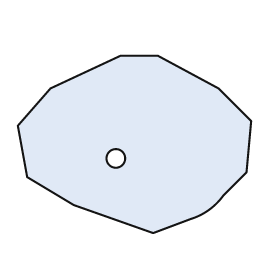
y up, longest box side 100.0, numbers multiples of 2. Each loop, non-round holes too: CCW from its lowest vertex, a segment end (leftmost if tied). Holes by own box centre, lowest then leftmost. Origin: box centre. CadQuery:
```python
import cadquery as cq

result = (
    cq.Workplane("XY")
    .moveTo(8.0, -38.0)
    .lineTo(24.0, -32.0)
    .threePointArc((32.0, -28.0), (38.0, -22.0))
    .lineTo(48.0, -12.0)
    .lineTo(50.0, 10.0)
    .lineTo(36.0, 24.0)
    .lineTo(10.0, 38.0)
    .lineTo(-6.0, 38.0)
    .lineTo(-36.0, 24.0)
    .lineTo(-50.0, 8.0)
    .lineTo(-46.0, -14.0)
    .lineTo(-26.0, -26.0)
    .close()
    .moveTo(-8.0, -6.0)
    .circle(4.0)
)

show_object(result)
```